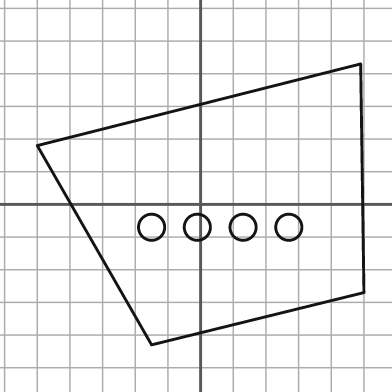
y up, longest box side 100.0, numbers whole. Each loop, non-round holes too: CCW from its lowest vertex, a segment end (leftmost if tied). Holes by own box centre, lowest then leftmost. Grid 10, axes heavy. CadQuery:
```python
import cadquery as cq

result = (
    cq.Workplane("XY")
    .moveTo(-15.0, -43.0)
    .lineTo(50.0, -27.0)
    .lineTo(49.0, 43.0)
    .lineTo(-50.0, 18.0)
    .close()
    .moveTo(-15.0, -7.0)
    .circle(4.0)
    .moveTo(-1.0, -7.0)
    .circle(4.0)
    .moveTo(13.0, -7.0)
    .circle(4.0)
    .moveTo(27.0, -7.0)
    .circle(4.0)
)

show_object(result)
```